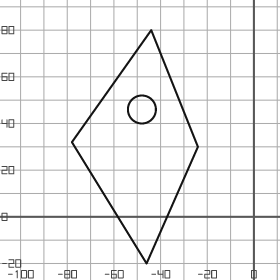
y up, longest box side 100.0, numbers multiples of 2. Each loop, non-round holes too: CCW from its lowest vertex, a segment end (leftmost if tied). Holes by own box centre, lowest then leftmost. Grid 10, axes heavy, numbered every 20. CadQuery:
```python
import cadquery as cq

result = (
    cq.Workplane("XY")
    .moveTo(-46.0, -20.0)
    .lineTo(-24.0, 30.0)
    .lineTo(-44.0, 80.0)
    .lineTo(-78.0, 32.0)
    .close()
    .moveTo(-48.0, 46.0)
    .circle(6.0)
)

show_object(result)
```